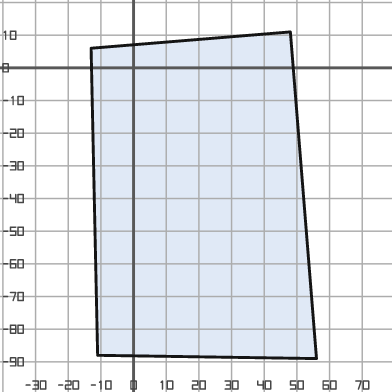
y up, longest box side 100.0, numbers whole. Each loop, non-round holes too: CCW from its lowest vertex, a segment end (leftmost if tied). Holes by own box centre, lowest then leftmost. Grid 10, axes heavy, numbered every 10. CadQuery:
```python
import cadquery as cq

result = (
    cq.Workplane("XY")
    .moveTo(56.0, -89.0)
    .lineTo(48.0, 11.0)
    .lineTo(-13.0, 6.0)
    .lineTo(-11.0, -88.0)
    .close()
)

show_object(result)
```